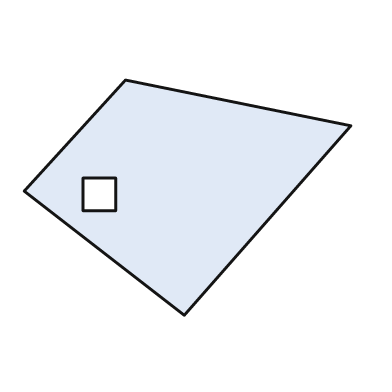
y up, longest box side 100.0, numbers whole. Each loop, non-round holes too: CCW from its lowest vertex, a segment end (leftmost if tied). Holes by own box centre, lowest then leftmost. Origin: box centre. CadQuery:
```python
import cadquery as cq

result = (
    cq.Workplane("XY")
    .moveTo(-1.0, -36.0)
    .lineTo(50.0, 22.0)
    .lineTo(-19.0, 36.0)
    .lineTo(-50.0, 2.0)
    .close()
    .moveTo(-32.0, -4.0)
    .lineTo(-22.0, -4.0)
    .lineTo(-22.0, 6.0)
    .lineTo(-32.0, 6.0)
    .close()
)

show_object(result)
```